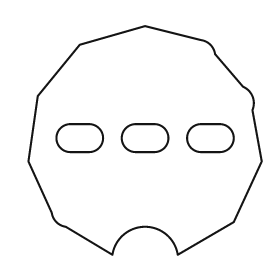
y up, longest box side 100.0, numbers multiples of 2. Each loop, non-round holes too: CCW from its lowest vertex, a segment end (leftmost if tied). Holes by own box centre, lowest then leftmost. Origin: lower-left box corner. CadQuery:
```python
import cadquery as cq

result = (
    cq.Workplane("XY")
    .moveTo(36.0, 0.0)
    .threePointArc((50.0, 12.0), (64.0, 0.0))
    .lineTo(88.0, 14.0)
    .lineTo(100.0, 40.0)
    .lineTo(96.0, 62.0)
    .threePointArc((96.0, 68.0), (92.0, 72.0))
    .lineTo(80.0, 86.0)
    .threePointArc((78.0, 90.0), (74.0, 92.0))
    .lineTo(50.0, 98.0)
    .lineTo(22.0, 90.0)
    .lineTo(4.0, 68.0)
    .lineTo(0.0, 40.0)
    .lineTo(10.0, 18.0)
    .threePointArc((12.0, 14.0), (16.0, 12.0))
    .close()
    .moveTo(18.0, 44.0)
    .lineTo(26.0, 44.0)
    .threePointArc((32.0, 50.0), (26.0, 56.0))
    .lineTo(18.0, 56.0)
    .threePointArc((12.0, 50.0), (18.0, 44.0))
    .close()
    .moveTo(46.0, 44.0)
    .lineTo(54.0, 44.0)
    .threePointArc((60.0, 50.0), (54.0, 56.0))
    .lineTo(46.0, 56.0)
    .threePointArc((40.0, 50.0), (46.0, 44.0))
    .close()
    .moveTo(74.0, 44.0)
    .lineTo(82.0, 44.0)
    .threePointArc((88.0, 50.0), (82.0, 56.0))
    .lineTo(74.0, 56.0)
    .threePointArc((68.0, 50.0), (74.0, 44.0))
    .close()
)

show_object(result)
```